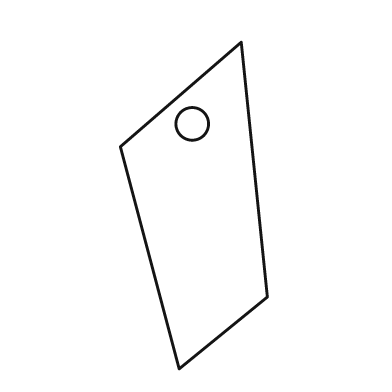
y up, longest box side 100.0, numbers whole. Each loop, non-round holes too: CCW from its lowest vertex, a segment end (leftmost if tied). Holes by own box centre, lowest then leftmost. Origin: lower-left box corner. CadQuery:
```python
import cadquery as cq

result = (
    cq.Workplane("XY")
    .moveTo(18.0, 0.0)
    .lineTo(45.0, 22.0)
    .lineTo(37.0, 100.0)
    .lineTo(0.0, 68.0)
    .close()
    .moveTo(22.0, 75.0)
    .circle(5.0)
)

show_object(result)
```